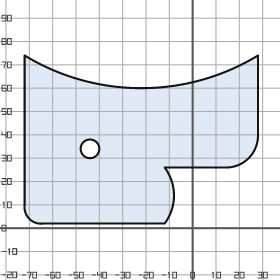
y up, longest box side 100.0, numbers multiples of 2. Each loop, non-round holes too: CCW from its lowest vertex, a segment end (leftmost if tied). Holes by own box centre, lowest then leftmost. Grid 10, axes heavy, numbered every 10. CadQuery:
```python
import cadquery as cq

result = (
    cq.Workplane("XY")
    .moveTo(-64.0, 2.0)
    .lineTo(-12.0, 2.0)
    .threePointArc((-8.0, 14.0), (-12.0, 26.0))
    .lineTo(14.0, 26.0)
    .threePointArc((24.0, 30.0), (28.0, 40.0))
    .lineTo(28.0, 74.0)
    .threePointArc((-22.0, 60.0), (-72.0, 74.0))
    .lineTo(-72.0, 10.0)
    .threePointArc((-70.0, 4.0), (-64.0, 2.0))
    .close()
    .moveTo(-44.0, 34.0)
    .circle(4.0)
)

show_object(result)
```